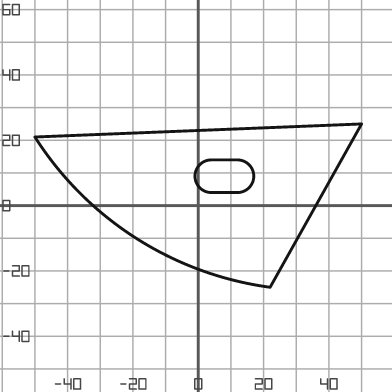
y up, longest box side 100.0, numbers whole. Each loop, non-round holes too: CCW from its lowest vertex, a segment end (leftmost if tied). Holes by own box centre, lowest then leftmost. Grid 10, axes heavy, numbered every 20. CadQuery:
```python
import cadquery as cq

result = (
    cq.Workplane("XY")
    .moveTo(22.0, -25.0)
    .lineTo(50.0, 25.0)
    .lineTo(-50.0, 21.0)
    .threePointArc((-19.0, -10.0), (22.0, -25.0))
    .close()
    .moveTo(4.0, 4.0)
    .lineTo(12.0, 4.0)
    .threePointArc((17.0, 9.0), (12.0, 14.0))
    .lineTo(4.0, 14.0)
    .threePointArc((-1.0, 9.0), (4.0, 4.0))
    .close()
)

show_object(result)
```